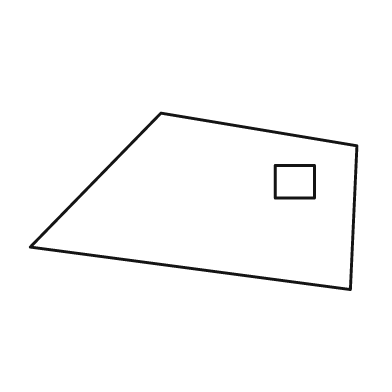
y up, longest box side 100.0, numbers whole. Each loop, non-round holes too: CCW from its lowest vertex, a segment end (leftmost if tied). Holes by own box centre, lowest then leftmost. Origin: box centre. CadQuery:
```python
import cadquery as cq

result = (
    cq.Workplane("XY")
    .moveTo(48.0, -27.0)
    .lineTo(50.0, 17.0)
    .lineTo(-10.0, 27.0)
    .lineTo(-50.0, -14.0)
    .close()
    .moveTo(25.0, 1.0)
    .lineTo(37.0, 1.0)
    .lineTo(37.0, 11.0)
    .lineTo(25.0, 11.0)
    .close()
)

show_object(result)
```